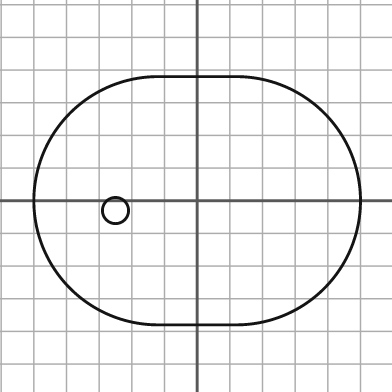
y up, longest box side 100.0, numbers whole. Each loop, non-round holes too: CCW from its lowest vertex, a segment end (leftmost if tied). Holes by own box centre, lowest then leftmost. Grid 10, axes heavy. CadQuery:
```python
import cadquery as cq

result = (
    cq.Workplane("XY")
    .moveTo(-12.0, -38.0)
    .lineTo(12.0, -38.0)
    .threePointArc((50.0, 0.0), (12.0, 38.0))
    .lineTo(-12.0, 38.0)
    .threePointArc((-50.0, 0.0), (-12.0, -38.0))
    .close()
    .moveTo(-25.0, -3.0)
    .circle(4.0)
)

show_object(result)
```